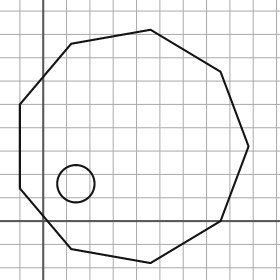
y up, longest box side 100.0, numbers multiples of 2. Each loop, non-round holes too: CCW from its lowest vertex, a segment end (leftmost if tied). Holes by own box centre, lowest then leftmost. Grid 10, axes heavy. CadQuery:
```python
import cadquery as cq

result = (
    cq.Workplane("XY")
    .moveTo(46.0, -18.0)
    .lineTo(76.0, 0.0)
    .lineTo(88.0, 32.0)
    .lineTo(76.0, 64.0)
    .lineTo(46.0, 82.0)
    .lineTo(12.0, 76.0)
    .lineTo(-10.0, 50.0)
    .lineTo(-10.0, 14.0)
    .lineTo(12.0, -12.0)
    .close()
    .moveTo(14.0, 16.0)
    .circle(8.0)
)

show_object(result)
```